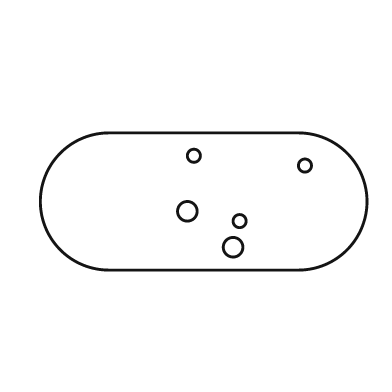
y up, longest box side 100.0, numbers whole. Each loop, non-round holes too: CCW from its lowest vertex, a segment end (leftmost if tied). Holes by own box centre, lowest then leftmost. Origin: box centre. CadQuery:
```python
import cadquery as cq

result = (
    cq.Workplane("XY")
    .moveTo(-29.0, -21.0)
    .lineTo(29.0, -21.0)
    .threePointArc((50.0, 0.0), (29.0, 21.0))
    .lineTo(-29.0, 21.0)
    .threePointArc((-50.0, 0.0), (-29.0, -21.0))
    .close()
    .moveTo(9.0, -14.0)
    .circle(3.0)
    .moveTo(11.0, -6.0)
    .circle(2.0)
    .moveTo(-5.0, -3.0)
    .circle(3.0)
    .moveTo(31.0, 11.0)
    .circle(2.0)
    .moveTo(-3.0, 14.0)
    .circle(2.0)
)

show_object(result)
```